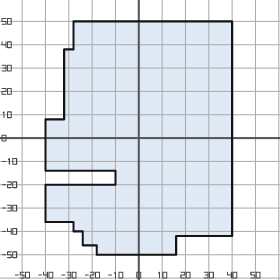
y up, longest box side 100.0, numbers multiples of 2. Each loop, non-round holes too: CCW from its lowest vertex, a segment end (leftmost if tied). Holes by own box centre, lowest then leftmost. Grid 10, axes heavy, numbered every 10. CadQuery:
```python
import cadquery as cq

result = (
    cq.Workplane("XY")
    .moveTo(-18.0, -50.0)
    .lineTo(16.0, -50.0)
    .lineTo(16.0, -42.0)
    .lineTo(40.0, -42.0)
    .lineTo(40.0, 50.0)
    .lineTo(-28.0, 50.0)
    .lineTo(-28.0, 38.0)
    .lineTo(-32.0, 38.0)
    .lineTo(-32.0, 8.0)
    .lineTo(-40.0, 8.0)
    .lineTo(-40.0, -14.0)
    .lineTo(-10.0, -14.0)
    .lineTo(-10.0, -20.0)
    .lineTo(-40.0, -20.0)
    .lineTo(-40.0, -36.0)
    .lineTo(-28.0, -36.0)
    .lineTo(-28.0, -40.0)
    .lineTo(-24.0, -40.0)
    .lineTo(-24.0, -46.0)
    .lineTo(-18.0, -46.0)
    .close()
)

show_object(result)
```